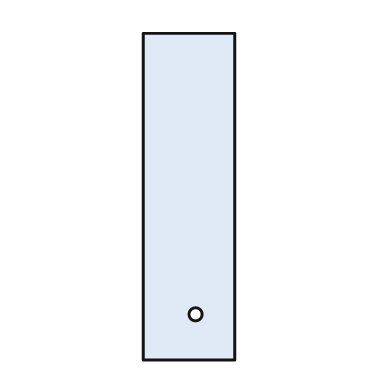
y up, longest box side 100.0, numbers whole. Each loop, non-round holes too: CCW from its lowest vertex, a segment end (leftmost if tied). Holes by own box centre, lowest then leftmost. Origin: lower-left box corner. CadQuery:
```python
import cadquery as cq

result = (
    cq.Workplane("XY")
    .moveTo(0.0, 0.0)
    .lineTo(28.0, 0.0)
    .lineTo(28.0, 100.0)
    .lineTo(0.0, 100.0)
    .close()
    .moveTo(16.0, 14.0)
    .circle(2.0)
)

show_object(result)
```